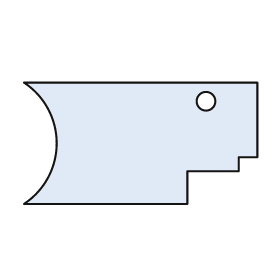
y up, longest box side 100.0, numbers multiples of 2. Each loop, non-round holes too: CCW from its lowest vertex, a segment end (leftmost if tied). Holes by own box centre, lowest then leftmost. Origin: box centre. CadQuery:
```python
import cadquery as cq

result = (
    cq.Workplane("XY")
    .moveTo(-50.0, -26.0)
    .lineTo(20.0, -26.0)
    .lineTo(20.0, -12.0)
    .lineTo(42.0, -12.0)
    .lineTo(42.0, -6.0)
    .lineTo(50.0, -6.0)
    .lineTo(50.0, 26.0)
    .lineTo(-50.0, 26.0)
    .threePointArc((-36.0, 0.0), (-50.0, -26.0))
    .close()
    .moveTo(28.0, 18.0)
    .circle(4.0)
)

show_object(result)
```